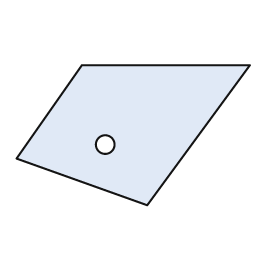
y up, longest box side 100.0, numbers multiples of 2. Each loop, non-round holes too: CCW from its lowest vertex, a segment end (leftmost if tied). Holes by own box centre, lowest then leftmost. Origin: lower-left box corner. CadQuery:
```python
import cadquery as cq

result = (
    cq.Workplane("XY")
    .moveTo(56.0, 0.0)
    .lineTo(100.0, 60.0)
    .lineTo(28.0, 60.0)
    .lineTo(0.0, 20.0)
    .close()
    .moveTo(38.0, 26.0)
    .circle(4.0)
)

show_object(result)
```